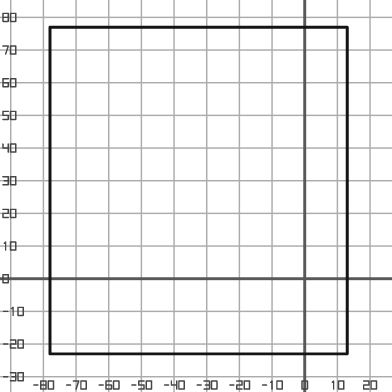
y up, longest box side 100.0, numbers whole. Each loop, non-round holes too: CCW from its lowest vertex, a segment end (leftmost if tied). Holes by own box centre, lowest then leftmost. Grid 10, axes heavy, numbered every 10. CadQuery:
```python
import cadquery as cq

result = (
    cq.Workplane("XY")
    .moveTo(-78.0, -23.0)
    .lineTo(13.0, -23.0)
    .lineTo(13.0, 77.0)
    .lineTo(-78.0, 77.0)
    .close()
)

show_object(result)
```